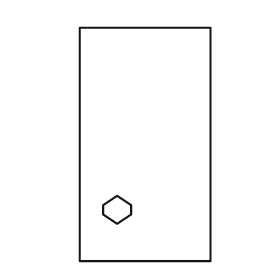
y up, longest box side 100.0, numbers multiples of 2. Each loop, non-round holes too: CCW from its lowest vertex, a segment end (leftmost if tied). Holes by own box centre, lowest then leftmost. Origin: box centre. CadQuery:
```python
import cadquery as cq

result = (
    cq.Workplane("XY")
    .moveTo(-28.0, -50.0)
    .lineTo(28.0, -50.0)
    .lineTo(28.0, 50.0)
    .lineTo(-28.0, 50.0)
    .close()
    .moveTo(-12.0, -34.0)
    .lineTo(-6.0, -30.0)
    .lineTo(-6.0, -26.0)
    .lineTo(-12.0, -22.0)
    .lineTo(-18.0, -26.0)
    .lineTo(-18.0, -30.0)
    .close()
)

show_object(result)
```